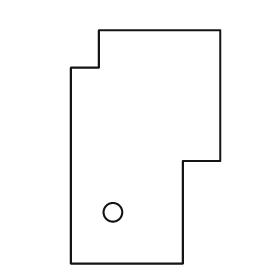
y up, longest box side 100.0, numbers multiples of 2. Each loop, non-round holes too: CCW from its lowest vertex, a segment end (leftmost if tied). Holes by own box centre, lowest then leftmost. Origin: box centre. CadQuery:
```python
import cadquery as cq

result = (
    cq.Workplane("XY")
    .moveTo(-32.0, -50.0)
    .lineTo(16.0, -50.0)
    .lineTo(16.0, -6.0)
    .lineTo(32.0, -6.0)
    .lineTo(32.0, 50.0)
    .lineTo(-20.0, 50.0)
    .lineTo(-20.0, 34.0)
    .lineTo(-32.0, 34.0)
    .close()
    .moveTo(-14.0, -28.0)
    .circle(4.0)
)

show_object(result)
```